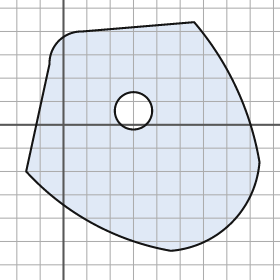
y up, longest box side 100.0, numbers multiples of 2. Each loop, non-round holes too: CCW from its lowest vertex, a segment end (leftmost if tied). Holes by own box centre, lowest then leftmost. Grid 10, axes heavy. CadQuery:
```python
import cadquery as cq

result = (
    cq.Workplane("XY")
    .moveTo(46.0, -54.0)
    .threePointArc((72.0, -42.0), (84.0, -16.0))
    .threePointArc((74.0, 16.0), (56.0, 44.0))
    .lineTo(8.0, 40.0)
    .threePointArc((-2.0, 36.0), (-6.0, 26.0))
    .lineTo(-16.0, -20.0)
    .threePointArc((12.0, -42.0), (46.0, -54.0))
    .close()
    .moveTo(30.0, 6.0)
    .circle(8.0)
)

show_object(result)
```